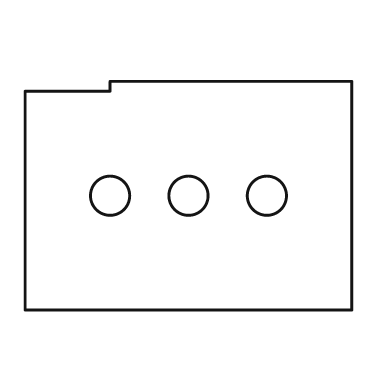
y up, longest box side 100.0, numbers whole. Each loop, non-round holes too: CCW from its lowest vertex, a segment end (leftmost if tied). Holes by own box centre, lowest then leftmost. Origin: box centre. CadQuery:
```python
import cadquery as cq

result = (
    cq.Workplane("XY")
    .moveTo(-50.0, -35.0)
    .lineTo(50.0, -35.0)
    .lineTo(50.0, 35.0)
    .lineTo(-24.0, 35.0)
    .lineTo(-24.0, 32.0)
    .lineTo(-50.0, 32.0)
    .close()
    .moveTo(-24.0, 0.0)
    .circle(6.0)
    .moveTo(0.0, 0.0)
    .circle(6.0)
    .moveTo(24.0, 0.0)
    .circle(6.0)
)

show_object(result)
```